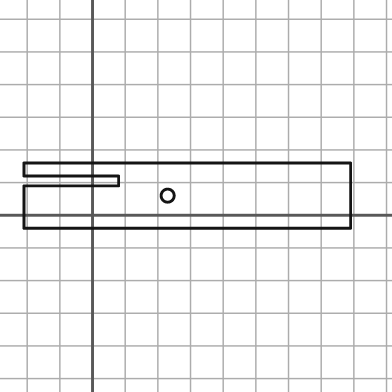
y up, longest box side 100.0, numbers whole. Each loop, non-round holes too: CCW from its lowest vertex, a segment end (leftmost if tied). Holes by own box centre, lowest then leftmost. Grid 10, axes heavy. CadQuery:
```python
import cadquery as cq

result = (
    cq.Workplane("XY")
    .moveTo(-21.0, -4.0)
    .lineTo(79.0, -4.0)
    .lineTo(79.0, 16.0)
    .lineTo(-21.0, 16.0)
    .lineTo(-21.0, 12.0)
    .lineTo(8.0, 12.0)
    .lineTo(8.0, 9.0)
    .lineTo(-21.0, 9.0)
    .close()
    .moveTo(23.0, 6.0)
    .circle(2.0)
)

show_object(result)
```